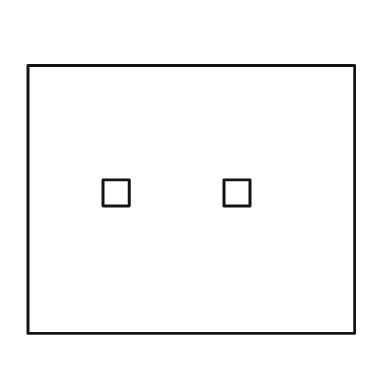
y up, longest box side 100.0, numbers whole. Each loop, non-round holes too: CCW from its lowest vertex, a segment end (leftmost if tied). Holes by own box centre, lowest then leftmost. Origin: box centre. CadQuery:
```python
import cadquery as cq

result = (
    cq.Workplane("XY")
    .moveTo(-50.0, -41.0)
    .lineTo(50.0, -41.0)
    .lineTo(50.0, 41.0)
    .lineTo(-50.0, 41.0)
    .close()
    .moveTo(-27.0, -2.0)
    .lineTo(-19.0, -2.0)
    .lineTo(-19.0, 6.0)
    .lineTo(-27.0, 6.0)
    .close()
    .moveTo(10.0, -2.0)
    .lineTo(18.0, -2.0)
    .lineTo(18.0, 6.0)
    .lineTo(10.0, 6.0)
    .close()
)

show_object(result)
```